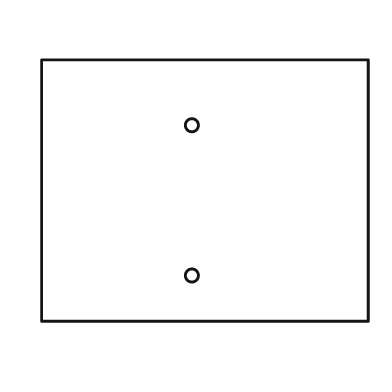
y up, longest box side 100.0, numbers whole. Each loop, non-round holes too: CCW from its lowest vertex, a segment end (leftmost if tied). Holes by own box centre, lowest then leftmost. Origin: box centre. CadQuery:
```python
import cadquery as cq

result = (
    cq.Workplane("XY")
    .moveTo(-50.0, -40.0)
    .lineTo(50.0, -40.0)
    .lineTo(50.0, 40.0)
    .lineTo(-50.0, 40.0)
    .close()
    .moveTo(-4.0, -26.0)
    .circle(2.0)
    .moveTo(-4.0, 20.0)
    .circle(2.0)
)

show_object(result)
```